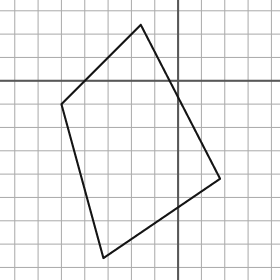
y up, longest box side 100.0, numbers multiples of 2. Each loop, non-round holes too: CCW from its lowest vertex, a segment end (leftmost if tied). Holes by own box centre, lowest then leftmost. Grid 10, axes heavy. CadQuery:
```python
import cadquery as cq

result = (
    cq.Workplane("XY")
    .moveTo(-32.0, -76.0)
    .lineTo(18.0, -42.0)
    .lineTo(-16.0, 24.0)
    .lineTo(-50.0, -10.0)
    .close()
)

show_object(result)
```